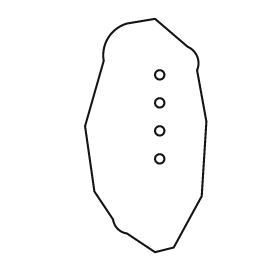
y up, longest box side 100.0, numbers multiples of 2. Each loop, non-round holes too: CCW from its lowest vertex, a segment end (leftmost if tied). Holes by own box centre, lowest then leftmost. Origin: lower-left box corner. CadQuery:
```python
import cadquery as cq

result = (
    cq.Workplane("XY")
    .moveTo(30.0, 0.0)
    .lineTo(38.0, 2.0)
    .lineTo(50.0, 24.0)
    .lineTo(52.0, 56.0)
    .lineTo(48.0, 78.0)
    .threePointArc((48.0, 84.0), (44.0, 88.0))
    .lineTo(30.0, 100.0)
    .lineTo(18.0, 98.0)
    .threePointArc((10.0, 92.0), (8.0, 82.0))
    .lineTo(0.0, 54.0)
    .lineTo(4.0, 26.0)
    .lineTo(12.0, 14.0)
    .threePointArc((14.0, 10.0), (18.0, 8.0))
    .close()
    .moveTo(32.0, 40.0)
    .circle(2.0)
    .moveTo(32.0, 52.0)
    .circle(2.0)
    .moveTo(32.0, 64.0)
    .circle(2.0)
    .moveTo(32.0, 76.0)
    .circle(2.0)
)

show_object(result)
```